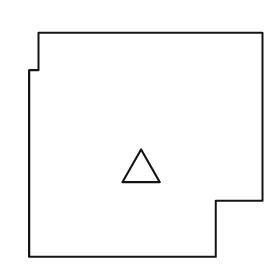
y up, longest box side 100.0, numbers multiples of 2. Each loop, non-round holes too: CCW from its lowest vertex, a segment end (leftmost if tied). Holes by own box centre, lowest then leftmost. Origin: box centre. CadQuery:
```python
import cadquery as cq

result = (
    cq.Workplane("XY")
    .moveTo(-50.0, -48.0)
    .lineTo(30.0, -48.0)
    .lineTo(30.0, -24.0)
    .lineTo(50.0, -24.0)
    .lineTo(50.0, 48.0)
    .lineTo(-46.0, 48.0)
    .lineTo(-46.0, 32.0)
    .lineTo(-50.0, 32.0)
    .close()
    .moveTo(-10.0, -16.0)
    .lineTo(6.0, -16.0)
    .lineTo(-2.0, -2.0)
    .close()
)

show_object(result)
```